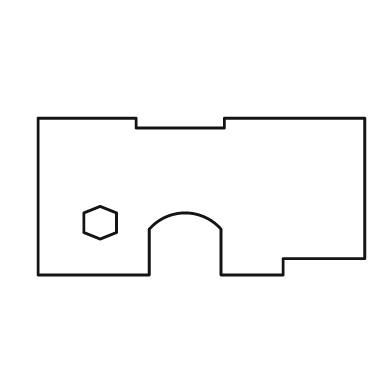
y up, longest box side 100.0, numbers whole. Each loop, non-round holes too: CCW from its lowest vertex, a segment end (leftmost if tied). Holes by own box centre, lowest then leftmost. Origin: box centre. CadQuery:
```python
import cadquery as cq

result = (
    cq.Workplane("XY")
    .moveTo(-50.0, -24.0)
    .lineTo(-16.0, -24.0)
    .lineTo(-16.0, -10.0)
    .threePointArc((-5.0, -5.0), (6.0, -10.0))
    .lineTo(6.0, -24.0)
    .lineTo(25.0, -24.0)
    .lineTo(25.0, -19.0)
    .lineTo(50.0, -19.0)
    .lineTo(50.0, 24.0)
    .lineTo(7.0, 24.0)
    .lineTo(7.0, 21.0)
    .lineTo(-20.0, 21.0)
    .lineTo(-20.0, 24.0)
    .lineTo(-50.0, 24.0)
    .close()
    .moveTo(-31.0, -13.0)
    .lineTo(-26.0, -11.0)
    .lineTo(-26.0, -5.0)
    .lineTo(-31.0, -3.0)
    .lineTo(-36.0, -5.0)
    .lineTo(-36.0, -11.0)
    .close()
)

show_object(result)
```